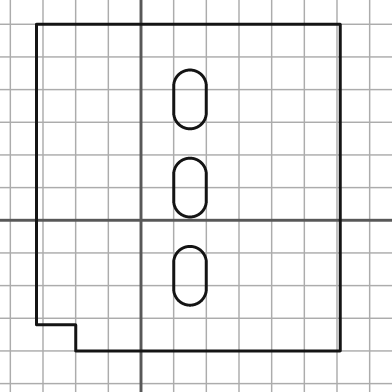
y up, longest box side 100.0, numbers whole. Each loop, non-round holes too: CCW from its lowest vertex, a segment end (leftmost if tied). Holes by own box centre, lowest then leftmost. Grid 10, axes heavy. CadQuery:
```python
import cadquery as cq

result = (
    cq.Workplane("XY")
    .moveTo(-20.0, -40.0)
    .lineTo(61.0, -40.0)
    .lineTo(61.0, 60.0)
    .lineTo(-32.0, 60.0)
    .lineTo(-32.0, -32.0)
    .lineTo(-20.0, -32.0)
    .close()
    .moveTo(10.0, -21.0)
    .threePointArc((15.0, -26.0), (20.0, -21.0))
    .lineTo(20.0, -13.0)
    .threePointArc((15.0, -8.0), (10.0, -13.0))
    .close()
    .moveTo(10.0, 6.0)
    .threePointArc((15.0, 1.0), (20.0, 6.0))
    .lineTo(20.0, 14.0)
    .threePointArc((15.0, 19.0), (10.0, 14.0))
    .close()
    .moveTo(10.0, 33.0)
    .threePointArc((15.0, 28.0), (20.0, 33.0))
    .lineTo(20.0, 41.0)
    .threePointArc((15.0, 46.0), (10.0, 41.0))
    .close()
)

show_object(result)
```